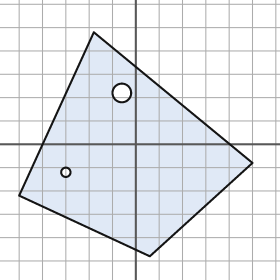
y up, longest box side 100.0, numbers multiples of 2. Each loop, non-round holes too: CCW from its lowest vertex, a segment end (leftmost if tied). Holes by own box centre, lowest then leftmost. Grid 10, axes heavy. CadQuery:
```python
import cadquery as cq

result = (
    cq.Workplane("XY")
    .moveTo(6.0, -48.0)
    .lineTo(50.0, -8.0)
    .lineTo(-18.0, 48.0)
    .lineTo(-50.0, -22.0)
    .close()
    .moveTo(-30.0, -12.0)
    .circle(2.0)
    .moveTo(-6.0, 22.0)
    .circle(4.0)
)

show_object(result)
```